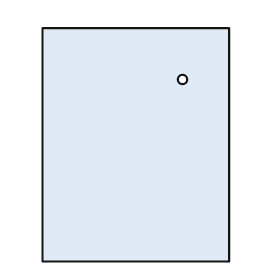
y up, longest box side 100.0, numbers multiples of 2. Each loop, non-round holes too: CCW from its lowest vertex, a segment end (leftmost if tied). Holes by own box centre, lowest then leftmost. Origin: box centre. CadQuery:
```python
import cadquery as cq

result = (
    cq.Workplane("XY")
    .moveTo(-40.0, -50.0)
    .lineTo(40.0, -50.0)
    .lineTo(40.0, 50.0)
    .lineTo(-40.0, 50.0)
    .close()
    .moveTo(20.0, 28.0)
    .circle(2.0)
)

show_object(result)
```